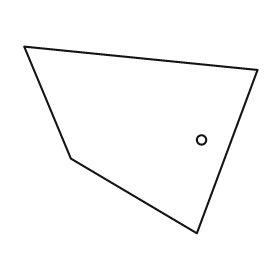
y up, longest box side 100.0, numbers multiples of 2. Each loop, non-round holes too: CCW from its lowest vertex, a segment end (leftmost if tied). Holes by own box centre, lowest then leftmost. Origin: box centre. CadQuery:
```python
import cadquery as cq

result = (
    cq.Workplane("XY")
    .moveTo(24.0, -40.0)
    .lineTo(50.0, 30.0)
    .lineTo(-50.0, 40.0)
    .lineTo(-30.0, -8.0)
    .close()
    .moveTo(26.0, 0.0)
    .circle(2.0)
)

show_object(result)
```